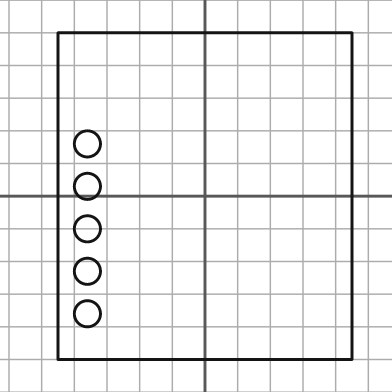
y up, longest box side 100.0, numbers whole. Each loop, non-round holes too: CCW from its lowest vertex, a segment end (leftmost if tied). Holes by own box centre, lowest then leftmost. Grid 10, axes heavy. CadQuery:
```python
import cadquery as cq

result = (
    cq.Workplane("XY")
    .moveTo(-45.0, -50.0)
    .lineTo(45.0, -50.0)
    .lineTo(45.0, 50.0)
    .lineTo(-45.0, 50.0)
    .close()
    .moveTo(-36.0, -36.0)
    .circle(4.0)
    .moveTo(-36.0, -23.0)
    .circle(4.0)
    .moveTo(-36.0, -10.0)
    .circle(4.0)
    .moveTo(-36.0, 3.0)
    .circle(4.0)
    .moveTo(-36.0, 16.0)
    .circle(4.0)
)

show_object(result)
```